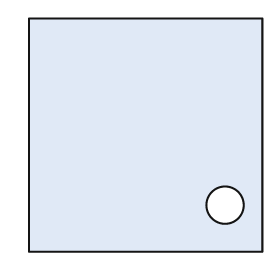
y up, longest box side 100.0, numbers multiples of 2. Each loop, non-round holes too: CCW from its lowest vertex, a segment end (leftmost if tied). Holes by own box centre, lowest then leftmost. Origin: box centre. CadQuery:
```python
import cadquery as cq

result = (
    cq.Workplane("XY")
    .moveTo(-50.0, -50.0)
    .lineTo(50.0, -50.0)
    .lineTo(50.0, 50.0)
    .lineTo(-50.0, 50.0)
    .close()
    .moveTo(34.0, -30.0)
    .circle(8.0)
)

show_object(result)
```